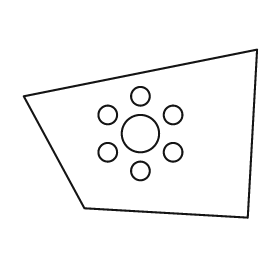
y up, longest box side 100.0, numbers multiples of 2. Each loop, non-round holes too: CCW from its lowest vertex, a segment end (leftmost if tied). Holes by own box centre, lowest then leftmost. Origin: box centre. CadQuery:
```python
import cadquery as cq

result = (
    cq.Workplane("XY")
    .moveTo(46.0, -36.0)
    .lineTo(50.0, 36.0)
    .lineTo(-50.0, 16.0)
    .lineTo(-24.0, -32.0)
    .close()
    .moveTo(0.0, -16.0)
    .circle(4.0)
    .moveTo(-14.0, -8.0)
    .circle(4.0)
    .moveTo(14.0, -8.0)
    .circle(4.0)
    .moveTo(0.0, 0.0)
    .circle(8.0)
    .moveTo(-14.0, 8.0)
    .circle(4.0)
    .moveTo(14.0, 8.0)
    .circle(4.0)
    .moveTo(0.0, 16.0)
    .circle(4.0)
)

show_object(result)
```